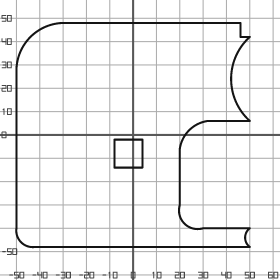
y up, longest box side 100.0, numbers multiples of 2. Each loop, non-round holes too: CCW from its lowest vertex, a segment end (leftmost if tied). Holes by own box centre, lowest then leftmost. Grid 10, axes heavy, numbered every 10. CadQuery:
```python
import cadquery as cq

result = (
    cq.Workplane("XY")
    .moveTo(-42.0, -48.0)
    .lineTo(50.0, -48.0)
    .threePointArc((48.0, -44.0), (50.0, -40.0))
    .lineTo(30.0, -40.0)
    .threePointArc((22.0, -38.0), (20.0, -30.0))
    .lineTo(20.0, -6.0)
    .threePointArc((24.0, 2.0), (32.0, 6.0))
    .lineTo(50.0, 6.0)
    .threePointArc((42.0, 24.0), (50.0, 42.0))
    .lineTo(46.0, 42.0)
    .lineTo(46.0, 48.0)
    .lineTo(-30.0, 48.0)
    .threePointArc((-44.0, 42.0), (-50.0, 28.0))
    .lineTo(-50.0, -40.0)
    .threePointArc((-48.0, -46.0), (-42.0, -48.0))
    .close()
    .moveTo(-8.0, -14.0)
    .lineTo(4.0, -14.0)
    .lineTo(4.0, -2.0)
    .lineTo(-8.0, -2.0)
    .close()
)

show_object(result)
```